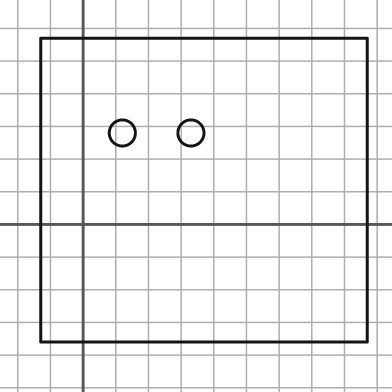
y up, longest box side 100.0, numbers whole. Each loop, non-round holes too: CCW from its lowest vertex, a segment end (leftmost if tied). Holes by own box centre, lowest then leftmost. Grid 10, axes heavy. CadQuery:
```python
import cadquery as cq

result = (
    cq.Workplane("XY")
    .moveTo(-13.0, -36.0)
    .lineTo(87.0, -36.0)
    .lineTo(87.0, 57.0)
    .lineTo(-13.0, 57.0)
    .close()
    .moveTo(12.0, 28.0)
    .circle(4.0)
    .moveTo(33.0, 28.0)
    .circle(4.0)
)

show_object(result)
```